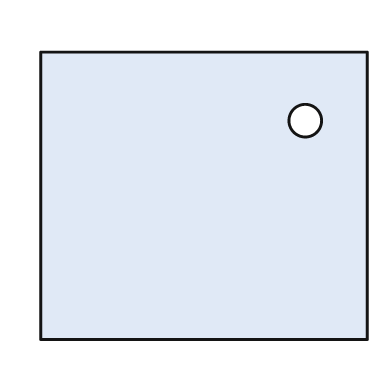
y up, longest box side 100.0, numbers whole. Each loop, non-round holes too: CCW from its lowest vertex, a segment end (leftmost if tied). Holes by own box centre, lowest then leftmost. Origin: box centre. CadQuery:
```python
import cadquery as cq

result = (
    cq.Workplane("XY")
    .moveTo(-50.0, -44.0)
    .lineTo(50.0, -44.0)
    .lineTo(50.0, 44.0)
    .lineTo(-50.0, 44.0)
    .close()
    .moveTo(31.0, 23.0)
    .circle(5.0)
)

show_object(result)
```